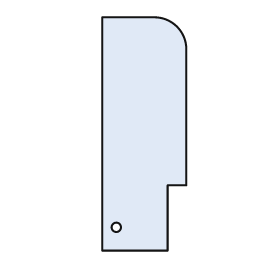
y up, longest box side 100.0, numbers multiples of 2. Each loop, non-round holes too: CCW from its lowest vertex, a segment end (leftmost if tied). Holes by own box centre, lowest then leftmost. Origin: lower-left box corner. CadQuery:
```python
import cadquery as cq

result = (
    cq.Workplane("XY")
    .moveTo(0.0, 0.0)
    .lineTo(28.0, 0.0)
    .lineTo(28.0, 28.0)
    .lineTo(36.0, 28.0)
    .lineTo(36.0, 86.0)
    .threePointArc((32.0, 96.0), (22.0, 100.0))
    .lineTo(0.0, 100.0)
    .close()
    .moveTo(6.0, 10.0)
    .circle(2.0)
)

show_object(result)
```